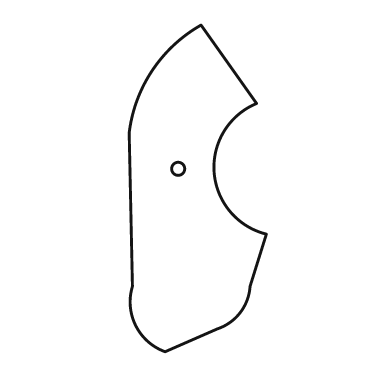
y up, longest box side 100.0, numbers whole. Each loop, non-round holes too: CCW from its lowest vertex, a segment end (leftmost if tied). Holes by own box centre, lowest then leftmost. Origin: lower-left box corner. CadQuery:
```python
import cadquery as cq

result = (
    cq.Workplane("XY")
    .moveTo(11.0, 0.0)
    .lineTo(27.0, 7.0)
    .threePointArc((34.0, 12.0), (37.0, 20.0))
    .lineTo(42.0, 36.0)
    .threePointArc((26.0, 55.0), (39.0, 76.0))
    .lineTo(22.0, 100.0)
    .threePointArc((7.0, 86.0), (0.0, 67.0))
    .lineTo(1.0, 20.0)
    .threePointArc((2.0, 8.0), (11.0, 0.0))
    .close()
    .moveTo(15.0, 56.0)
    .circle(2.0)
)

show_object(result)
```